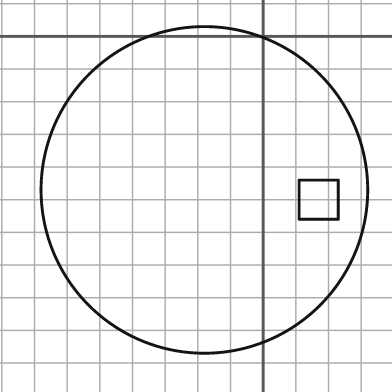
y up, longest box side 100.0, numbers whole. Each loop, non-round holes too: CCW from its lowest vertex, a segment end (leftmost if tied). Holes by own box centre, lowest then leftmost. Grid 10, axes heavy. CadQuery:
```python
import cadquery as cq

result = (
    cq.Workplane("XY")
    .moveTo(-18.0, -47.0)
    .circle(50.0)
    .moveTo(11.0, -56.0)
    .lineTo(23.0, -56.0)
    .lineTo(23.0, -44.0)
    .lineTo(11.0, -44.0)
    .close()
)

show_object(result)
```